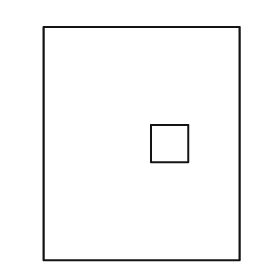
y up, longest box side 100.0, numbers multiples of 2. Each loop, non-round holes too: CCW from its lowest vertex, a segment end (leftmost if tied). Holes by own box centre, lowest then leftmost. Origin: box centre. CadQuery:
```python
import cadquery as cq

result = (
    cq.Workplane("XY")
    .moveTo(-42.0, -50.0)
    .lineTo(42.0, -50.0)
    .lineTo(42.0, 50.0)
    .lineTo(-42.0, 50.0)
    .close()
    .moveTo(4.0, -8.0)
    .lineTo(20.0, -8.0)
    .lineTo(20.0, 8.0)
    .lineTo(4.0, 8.0)
    .close()
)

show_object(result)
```